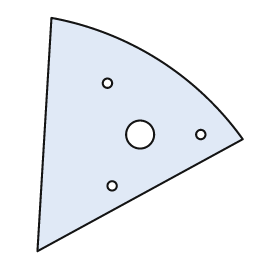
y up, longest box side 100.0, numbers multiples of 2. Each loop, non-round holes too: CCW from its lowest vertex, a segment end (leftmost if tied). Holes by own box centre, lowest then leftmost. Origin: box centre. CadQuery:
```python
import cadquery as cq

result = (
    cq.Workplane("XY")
    .moveTo(-44.0, -50.0)
    .lineTo(44.0, -2.0)
    .threePointArc((8.0, 32.0), (-38.0, 50.0))
    .close()
    .moveTo(-12.0, -22.0)
    .circle(2.0)
    .moveTo(0.0, 0.0)
    .circle(6.0)
    .moveTo(26.0, 0.0)
    .circle(2.0)
    .moveTo(-14.0, 22.0)
    .circle(2.0)
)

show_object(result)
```